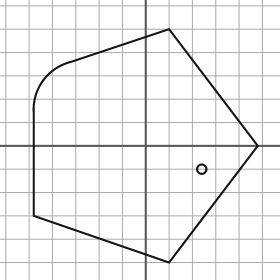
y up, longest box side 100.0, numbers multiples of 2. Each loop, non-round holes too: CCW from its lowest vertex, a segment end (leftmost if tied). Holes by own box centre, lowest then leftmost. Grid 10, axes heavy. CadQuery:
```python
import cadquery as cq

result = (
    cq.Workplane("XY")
    .moveTo(10.0, -50.0)
    .lineTo(48.0, 0.0)
    .lineTo(10.0, 50.0)
    .lineTo(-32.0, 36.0)
    .threePointArc((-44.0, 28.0), (-48.0, 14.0))
    .lineTo(-48.0, -30.0)
    .close()
    .moveTo(24.0, -10.0)
    .circle(2.0)
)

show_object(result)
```